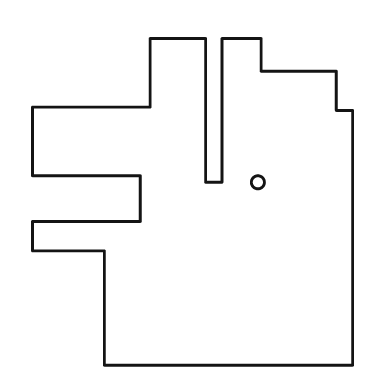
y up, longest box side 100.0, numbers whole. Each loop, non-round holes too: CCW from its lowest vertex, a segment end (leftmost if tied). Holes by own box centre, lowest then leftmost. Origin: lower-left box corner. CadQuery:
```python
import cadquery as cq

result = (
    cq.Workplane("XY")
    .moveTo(22.0, 0.0)
    .lineTo(98.0, 0.0)
    .lineTo(98.0, 78.0)
    .lineTo(93.0, 78.0)
    .lineTo(93.0, 90.0)
    .lineTo(70.0, 90.0)
    .lineTo(70.0, 100.0)
    .lineTo(58.0, 100.0)
    .lineTo(58.0, 56.0)
    .lineTo(53.0, 56.0)
    .lineTo(53.0, 100.0)
    .lineTo(36.0, 100.0)
    .lineTo(36.0, 79.0)
    .lineTo(0.0, 79.0)
    .lineTo(0.0, 58.0)
    .lineTo(33.0, 58.0)
    .lineTo(33.0, 44.0)
    .lineTo(0.0, 44.0)
    .lineTo(0.0, 35.0)
    .lineTo(22.0, 35.0)
    .close()
    .moveTo(69.0, 56.0)
    .circle(2.0)
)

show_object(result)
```